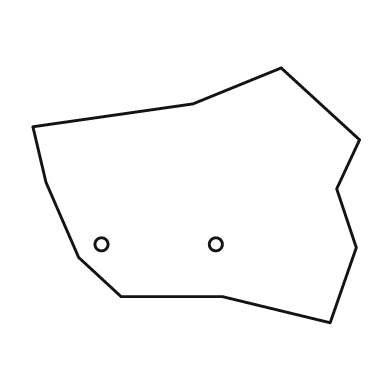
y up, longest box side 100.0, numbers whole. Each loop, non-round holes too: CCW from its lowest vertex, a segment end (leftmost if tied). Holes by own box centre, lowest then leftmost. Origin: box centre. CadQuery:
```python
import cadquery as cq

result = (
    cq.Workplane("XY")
    .moveTo(41.0, -39.0)
    .lineTo(49.0, -16.0)
    .lineTo(43.0, 2.0)
    .lineTo(50.0, 17.0)
    .lineTo(26.0, 39.0)
    .lineTo(-1.0, 28.0)
    .lineTo(-50.0, 21.0)
    .lineTo(-46.0, 4.0)
    .lineTo(-36.0, -19.0)
    .lineTo(-23.0, -31.0)
    .lineTo(8.0, -31.0)
    .close()
    .moveTo(-29.0, -15.0)
    .circle(2.0)
    .moveTo(6.0, -15.0)
    .circle(2.0)
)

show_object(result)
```